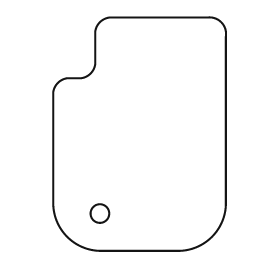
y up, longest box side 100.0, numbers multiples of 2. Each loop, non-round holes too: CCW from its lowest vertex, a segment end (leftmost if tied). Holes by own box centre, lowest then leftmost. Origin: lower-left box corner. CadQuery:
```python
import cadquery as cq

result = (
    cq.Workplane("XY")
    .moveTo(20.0, 0.0)
    .lineTo(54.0, 0.0)
    .threePointArc((68.0, 6.0), (74.0, 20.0))
    .lineTo(74.0, 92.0)
    .threePointArc((72.0, 98.0), (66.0, 100.0))
    .lineTo(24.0, 100.0)
    .threePointArc((20.0, 98.0), (18.0, 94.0))
    .lineTo(18.0, 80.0)
    .threePointArc((16.0, 76.0), (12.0, 74.0))
    .lineTo(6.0, 74.0)
    .threePointArc((2.0, 72.0), (0.0, 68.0))
    .lineTo(0.0, 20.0)
    .threePointArc((6.0, 6.0), (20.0, 0.0))
    .close()
    .moveTo(20.0, 16.0)
    .circle(4.0)
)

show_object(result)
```